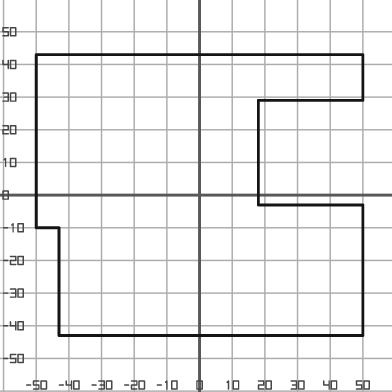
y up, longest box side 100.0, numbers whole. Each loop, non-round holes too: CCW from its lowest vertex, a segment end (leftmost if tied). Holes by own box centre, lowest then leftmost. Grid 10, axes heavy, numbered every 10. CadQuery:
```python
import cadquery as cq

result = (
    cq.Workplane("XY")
    .moveTo(-43.0, -43.0)
    .lineTo(50.0, -43.0)
    .lineTo(50.0, -3.0)
    .lineTo(18.0, -3.0)
    .lineTo(18.0, 29.0)
    .lineTo(50.0, 29.0)
    .lineTo(50.0, 43.0)
    .lineTo(-50.0, 43.0)
    .lineTo(-50.0, -10.0)
    .lineTo(-43.0, -10.0)
    .close()
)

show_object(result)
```